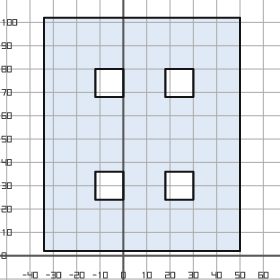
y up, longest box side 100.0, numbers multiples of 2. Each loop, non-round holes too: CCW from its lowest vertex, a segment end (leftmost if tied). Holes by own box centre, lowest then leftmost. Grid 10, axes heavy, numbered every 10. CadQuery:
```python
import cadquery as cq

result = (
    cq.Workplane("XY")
    .moveTo(-34.0, 2.0)
    .lineTo(50.0, 2.0)
    .lineTo(50.0, 102.0)
    .lineTo(-34.0, 102.0)
    .close()
    .moveTo(-12.0, 24.0)
    .lineTo(0.0, 24.0)
    .lineTo(0.0, 36.0)
    .lineTo(-12.0, 36.0)
    .close()
    .moveTo(18.0, 24.0)
    .lineTo(30.0, 24.0)
    .lineTo(30.0, 36.0)
    .lineTo(18.0, 36.0)
    .close()
    .moveTo(-12.0, 68.0)
    .lineTo(0.0, 68.0)
    .lineTo(0.0, 80.0)
    .lineTo(-12.0, 80.0)
    .close()
    .moveTo(18.0, 68.0)
    .lineTo(30.0, 68.0)
    .lineTo(30.0, 80.0)
    .lineTo(18.0, 80.0)
    .close()
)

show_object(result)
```